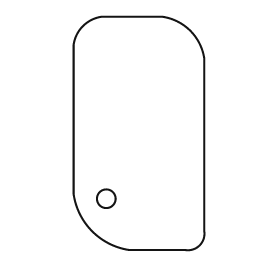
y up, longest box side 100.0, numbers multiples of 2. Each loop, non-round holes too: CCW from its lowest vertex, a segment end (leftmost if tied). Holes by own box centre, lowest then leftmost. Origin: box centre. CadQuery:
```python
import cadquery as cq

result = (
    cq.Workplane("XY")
    .moveTo(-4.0, -50.0)
    .lineTo(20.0, -50.0)
    .threePointArc((26.0, -48.0), (28.0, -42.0))
    .lineTo(28.0, 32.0)
    .threePointArc((22.0, 44.0), (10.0, 50.0))
    .lineTo(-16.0, 50.0)
    .threePointArc((-24.0, 46.0), (-28.0, 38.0))
    .lineTo(-28.0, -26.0)
    .threePointArc((-20.0, -42.0), (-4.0, -50.0))
    .close()
    .moveTo(-14.0, -28.0)
    .circle(4.0)
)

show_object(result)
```